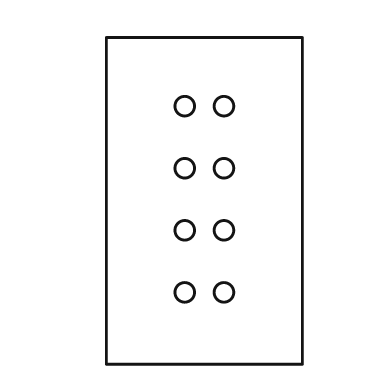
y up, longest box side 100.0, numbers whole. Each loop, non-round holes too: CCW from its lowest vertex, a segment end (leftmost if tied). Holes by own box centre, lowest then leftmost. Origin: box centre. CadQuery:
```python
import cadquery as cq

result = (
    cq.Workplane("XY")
    .moveTo(-30.0, -50.0)
    .lineTo(30.0, -50.0)
    .lineTo(30.0, 50.0)
    .lineTo(-30.0, 50.0)
    .close()
    .moveTo(-6.0, -28.0)
    .circle(3.0)
    .moveTo(6.0, -28.0)
    .circle(3.0)
    .moveTo(-6.0, -9.0)
    .circle(3.0)
    .moveTo(6.0, -9.0)
    .circle(3.0)
    .moveTo(-6.0, 10.0)
    .circle(3.0)
    .moveTo(6.0, 10.0)
    .circle(3.0)
    .moveTo(-6.0, 29.0)
    .circle(3.0)
    .moveTo(6.0, 29.0)
    .circle(3.0)
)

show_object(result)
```